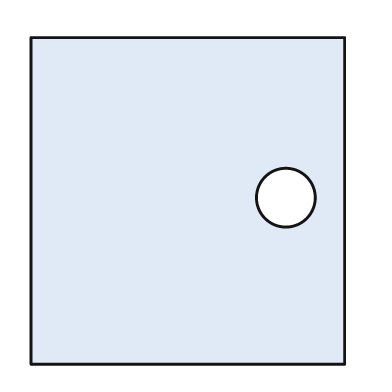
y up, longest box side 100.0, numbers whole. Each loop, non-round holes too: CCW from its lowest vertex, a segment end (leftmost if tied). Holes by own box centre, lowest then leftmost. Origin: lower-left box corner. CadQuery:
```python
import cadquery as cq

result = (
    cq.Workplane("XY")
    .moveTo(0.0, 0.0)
    .lineTo(96.0, 0.0)
    .lineTo(96.0, 100.0)
    .lineTo(0.0, 100.0)
    .close()
    .moveTo(78.0, 51.0)
    .circle(9.0)
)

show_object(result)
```